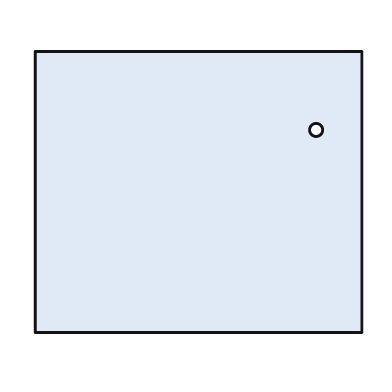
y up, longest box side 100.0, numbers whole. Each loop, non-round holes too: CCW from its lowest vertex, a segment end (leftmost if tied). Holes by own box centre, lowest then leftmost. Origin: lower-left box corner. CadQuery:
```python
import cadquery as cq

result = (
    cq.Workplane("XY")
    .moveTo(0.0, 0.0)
    .lineTo(100.0, 0.0)
    .lineTo(100.0, 86.0)
    .lineTo(0.0, 86.0)
    .close()
    .moveTo(86.0, 62.0)
    .circle(2.0)
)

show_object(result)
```